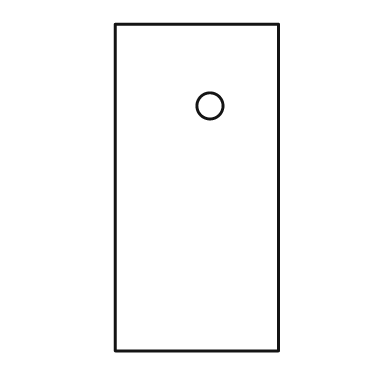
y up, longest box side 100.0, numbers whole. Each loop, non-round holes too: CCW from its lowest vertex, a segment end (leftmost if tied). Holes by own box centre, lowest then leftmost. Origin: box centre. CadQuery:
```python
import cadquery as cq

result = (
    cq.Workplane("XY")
    .moveTo(-25.0, -50.0)
    .lineTo(25.0, -50.0)
    .lineTo(25.0, 50.0)
    .lineTo(-25.0, 50.0)
    .close()
    .moveTo(4.0, 25.0)
    .circle(4.0)
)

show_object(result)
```